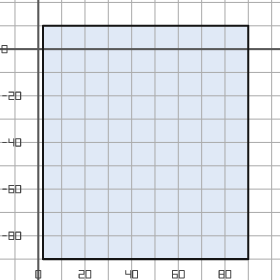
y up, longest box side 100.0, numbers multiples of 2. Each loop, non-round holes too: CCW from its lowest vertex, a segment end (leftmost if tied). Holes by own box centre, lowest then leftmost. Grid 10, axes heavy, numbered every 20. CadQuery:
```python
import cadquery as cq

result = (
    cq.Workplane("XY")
    .moveTo(2.0, -90.0)
    .lineTo(90.0, -90.0)
    .lineTo(90.0, 10.0)
    .lineTo(2.0, 10.0)
    .close()
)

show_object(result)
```